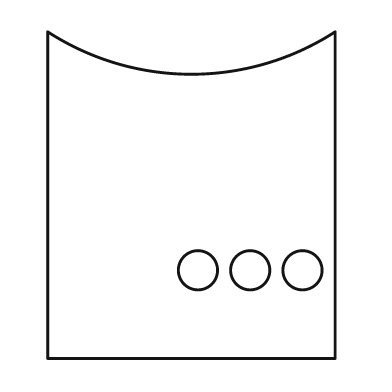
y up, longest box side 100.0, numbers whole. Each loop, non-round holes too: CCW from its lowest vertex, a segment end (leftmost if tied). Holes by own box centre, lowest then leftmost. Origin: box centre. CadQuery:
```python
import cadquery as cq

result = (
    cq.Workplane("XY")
    .moveTo(-44.0, -50.0)
    .lineTo(44.0, -50.0)
    .lineTo(44.0, 50.0)
    .threePointArc((0.0, 37.0), (-44.0, 50.0))
    .close()
    .moveTo(2.0, -23.0)
    .circle(6.0)
    .moveTo(18.0, -23.0)
    .circle(6.0)
    .moveTo(34.0, -23.0)
    .circle(6.0)
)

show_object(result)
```